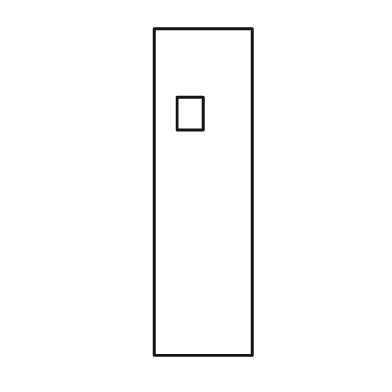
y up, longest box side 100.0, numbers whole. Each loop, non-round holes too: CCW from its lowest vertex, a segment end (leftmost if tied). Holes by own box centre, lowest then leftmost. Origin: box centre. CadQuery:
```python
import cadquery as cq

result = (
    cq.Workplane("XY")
    .moveTo(-15.0, -50.0)
    .lineTo(15.0, -50.0)
    .lineTo(15.0, 50.0)
    .lineTo(-15.0, 50.0)
    .close()
    .moveTo(-8.0, 19.0)
    .lineTo(0.0, 19.0)
    .lineTo(0.0, 29.0)
    .lineTo(-8.0, 29.0)
    .close()
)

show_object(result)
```